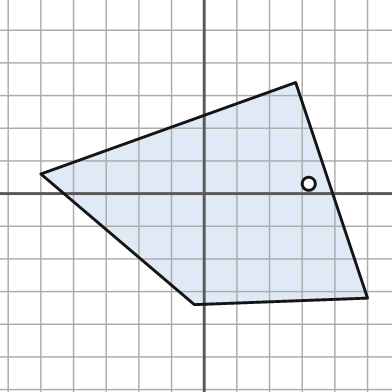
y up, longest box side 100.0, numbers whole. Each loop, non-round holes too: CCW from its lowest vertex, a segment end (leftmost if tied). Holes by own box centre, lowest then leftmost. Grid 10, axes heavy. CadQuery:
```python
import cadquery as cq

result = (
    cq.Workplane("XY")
    .moveTo(-3.0, -34.0)
    .lineTo(50.0, -32.0)
    .lineTo(28.0, 34.0)
    .lineTo(-50.0, 6.0)
    .close()
    .moveTo(32.0, 3.0)
    .circle(2.0)
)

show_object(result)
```